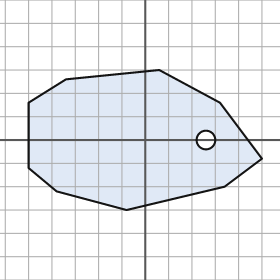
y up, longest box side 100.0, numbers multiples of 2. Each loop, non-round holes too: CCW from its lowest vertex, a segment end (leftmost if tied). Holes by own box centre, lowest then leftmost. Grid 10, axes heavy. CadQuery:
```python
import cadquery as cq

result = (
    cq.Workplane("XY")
    .moveTo(-8.0, -30.0)
    .lineTo(34.0, -20.0)
    .lineTo(50.0, -8.0)
    .lineTo(32.0, 16.0)
    .lineTo(6.0, 30.0)
    .lineTo(-34.0, 26.0)
    .lineTo(-50.0, 16.0)
    .lineTo(-50.0, -12.0)
    .lineTo(-38.0, -22.0)
    .close()
    .moveTo(26.0, 0.0)
    .circle(4.0)
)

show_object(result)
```